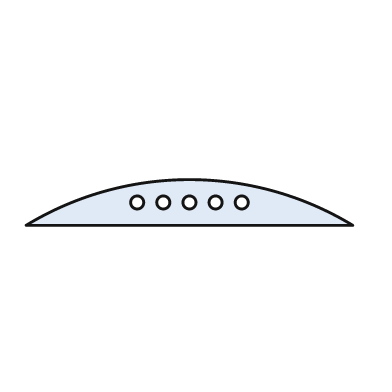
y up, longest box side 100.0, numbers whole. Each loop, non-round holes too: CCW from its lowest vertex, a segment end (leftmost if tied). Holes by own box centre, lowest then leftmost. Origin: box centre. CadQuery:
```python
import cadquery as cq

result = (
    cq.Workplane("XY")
    .moveTo(-50.0, -7.0)
    .lineTo(50.0, -7.0)
    .threePointArc((0.0, 7.0), (-50.0, -7.0))
    .close()
    .moveTo(-16.0, 0.0)
    .circle(2.0)
    .moveTo(-8.0, 0.0)
    .circle(2.0)
    .moveTo(0.0, 0.0)
    .circle(2.0)
    .moveTo(8.0, 0.0)
    .circle(2.0)
    .moveTo(16.0, 0.0)
    .circle(2.0)
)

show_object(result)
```